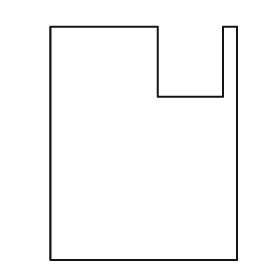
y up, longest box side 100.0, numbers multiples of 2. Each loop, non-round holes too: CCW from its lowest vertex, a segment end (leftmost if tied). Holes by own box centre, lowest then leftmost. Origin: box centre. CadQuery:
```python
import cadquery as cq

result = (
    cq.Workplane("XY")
    .moveTo(-40.0, -50.0)
    .lineTo(40.0, -50.0)
    .lineTo(40.0, 50.0)
    .lineTo(34.0, 50.0)
    .lineTo(34.0, 20.0)
    .lineTo(6.0, 20.0)
    .lineTo(6.0, 50.0)
    .lineTo(-40.0, 50.0)
    .close()
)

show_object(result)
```